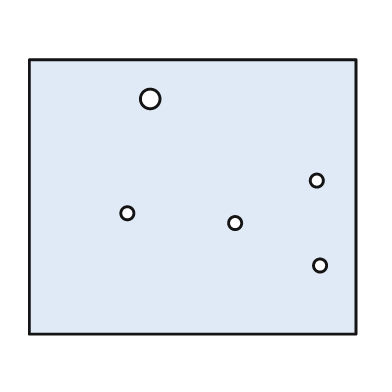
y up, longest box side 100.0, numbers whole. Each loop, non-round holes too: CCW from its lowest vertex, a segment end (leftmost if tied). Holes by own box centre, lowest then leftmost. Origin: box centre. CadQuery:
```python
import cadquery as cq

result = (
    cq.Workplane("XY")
    .moveTo(-50.0, -42.0)
    .lineTo(50.0, -42.0)
    .lineTo(50.0, 42.0)
    .lineTo(-50.0, 42.0)
    .close()
    .moveTo(39.0, -21.0)
    .circle(2.0)
    .moveTo(13.0, -8.0)
    .circle(2.0)
    .moveTo(-20.0, -5.0)
    .circle(2.0)
    .moveTo(38.0, 5.0)
    .circle(2.0)
    .moveTo(-13.0, 30.0)
    .circle(3.0)
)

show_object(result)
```